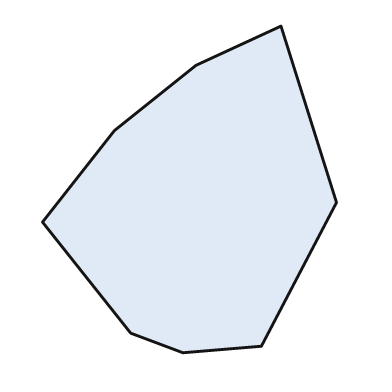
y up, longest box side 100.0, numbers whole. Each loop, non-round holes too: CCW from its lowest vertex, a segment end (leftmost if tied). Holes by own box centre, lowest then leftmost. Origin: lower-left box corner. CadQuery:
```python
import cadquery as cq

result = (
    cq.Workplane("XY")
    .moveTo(43.0, 0.0)
    .lineTo(67.0, 2.0)
    .lineTo(90.0, 46.0)
    .lineTo(73.0, 100.0)
    .lineTo(47.0, 88.0)
    .lineTo(22.0, 68.0)
    .lineTo(0.0, 40.0)
    .lineTo(27.0, 6.0)
    .close()
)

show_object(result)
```